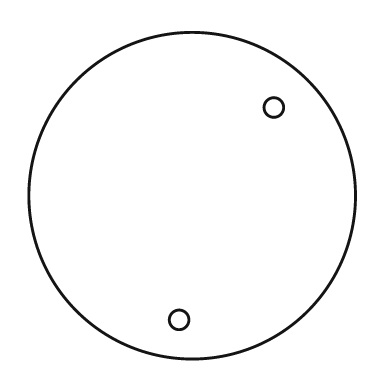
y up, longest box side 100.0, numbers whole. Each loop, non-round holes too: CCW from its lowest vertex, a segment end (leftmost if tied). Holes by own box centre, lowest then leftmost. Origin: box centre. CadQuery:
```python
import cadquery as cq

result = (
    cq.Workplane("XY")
    .moveTo(0.0, 0.0)
    .circle(50.0)
    .moveTo(-4.0, -38.0)
    .circle(3.0)
    .moveTo(25.0, 27.0)
    .circle(3.0)
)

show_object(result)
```